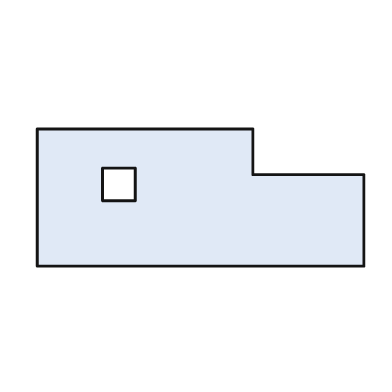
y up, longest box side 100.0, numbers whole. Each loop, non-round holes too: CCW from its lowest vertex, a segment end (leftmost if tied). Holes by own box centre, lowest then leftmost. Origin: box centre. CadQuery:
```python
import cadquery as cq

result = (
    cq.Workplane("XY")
    .moveTo(-50.0, -21.0)
    .lineTo(50.0, -21.0)
    .lineTo(50.0, 7.0)
    .lineTo(16.0, 7.0)
    .lineTo(16.0, 21.0)
    .lineTo(-50.0, 21.0)
    .close()
    .moveTo(-30.0, -1.0)
    .lineTo(-20.0, -1.0)
    .lineTo(-20.0, 9.0)
    .lineTo(-30.0, 9.0)
    .close()
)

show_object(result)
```